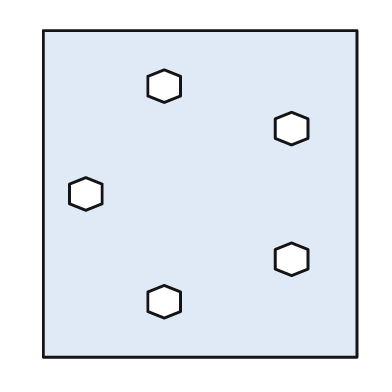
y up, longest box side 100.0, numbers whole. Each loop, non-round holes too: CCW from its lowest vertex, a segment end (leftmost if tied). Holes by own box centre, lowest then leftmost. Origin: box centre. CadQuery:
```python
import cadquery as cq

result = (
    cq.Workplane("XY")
    .moveTo(-48.0, -50.0)
    .lineTo(48.0, -50.0)
    .lineTo(48.0, 50.0)
    .lineTo(-48.0, 50.0)
    .close()
    .moveTo(-11.0, -38.0)
    .lineTo(-6.0, -36.0)
    .lineTo(-6.0, -30.0)
    .lineTo(-11.0, -28.0)
    .lineTo(-16.0, -30.0)
    .lineTo(-16.0, -36.0)
    .close()
    .moveTo(28.0, -25.0)
    .lineTo(33.0, -23.0)
    .lineTo(33.0, -17.0)
    .lineTo(28.0, -15.0)
    .lineTo(23.0, -17.0)
    .lineTo(23.0, -23.0)
    .close()
    .moveTo(-35.0, -5.0)
    .lineTo(-30.0, -3.0)
    .lineTo(-30.0, 3.0)
    .lineTo(-35.0, 5.0)
    .lineTo(-40.0, 3.0)
    .lineTo(-40.0, -3.0)
    .close()
    .moveTo(28.0, 15.0)
    .lineTo(33.0, 17.0)
    .lineTo(33.0, 23.0)
    .lineTo(28.0, 25.0)
    .lineTo(23.0, 23.0)
    .lineTo(23.0, 17.0)
    .close()
    .moveTo(-11.0, 28.0)
    .lineTo(-6.0, 30.0)
    .lineTo(-6.0, 36.0)
    .lineTo(-11.0, 38.0)
    .lineTo(-16.0, 36.0)
    .lineTo(-16.0, 30.0)
    .close()
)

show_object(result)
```